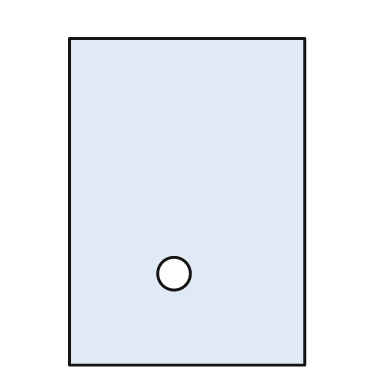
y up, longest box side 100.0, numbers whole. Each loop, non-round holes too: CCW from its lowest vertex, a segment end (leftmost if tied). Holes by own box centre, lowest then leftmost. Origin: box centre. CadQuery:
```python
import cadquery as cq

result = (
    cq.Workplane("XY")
    .moveTo(-36.0, -50.0)
    .lineTo(36.0, -50.0)
    .lineTo(36.0, 50.0)
    .lineTo(-36.0, 50.0)
    .close()
    .moveTo(-4.0, -22.0)
    .circle(5.0)
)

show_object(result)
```